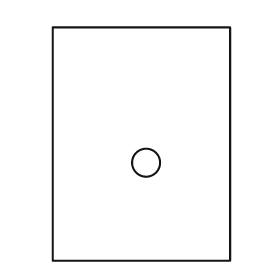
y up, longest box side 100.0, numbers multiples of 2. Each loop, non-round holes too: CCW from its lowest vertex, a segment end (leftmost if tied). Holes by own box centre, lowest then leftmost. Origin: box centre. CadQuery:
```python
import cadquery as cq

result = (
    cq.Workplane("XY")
    .moveTo(-38.0, -50.0)
    .lineTo(38.0, -50.0)
    .lineTo(38.0, 50.0)
    .lineTo(-38.0, 50.0)
    .close()
    .moveTo(2.0, -8.0)
    .circle(6.0)
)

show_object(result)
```